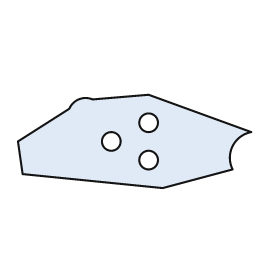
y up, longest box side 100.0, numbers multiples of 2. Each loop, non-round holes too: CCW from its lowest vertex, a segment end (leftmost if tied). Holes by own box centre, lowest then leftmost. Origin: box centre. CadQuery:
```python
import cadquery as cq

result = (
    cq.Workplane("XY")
    .moveTo(12.0, -20.0)
    .lineTo(42.0, -12.0)
    .threePointArc((42.0, -2.0), (50.0, 4.0))
    .lineTo(6.0, 20.0)
    .lineTo(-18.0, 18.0)
    .threePointArc((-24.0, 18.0), (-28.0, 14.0))
    .lineTo(-50.0, 0.0)
    .lineTo(-48.0, -14.0)
    .close()
    .moveTo(6.0, -8.0)
    .circle(4.0)
    .moveTo(-10.0, 0.0)
    .circle(4.0)
    .moveTo(6.0, 8.0)
    .circle(4.0)
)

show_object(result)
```